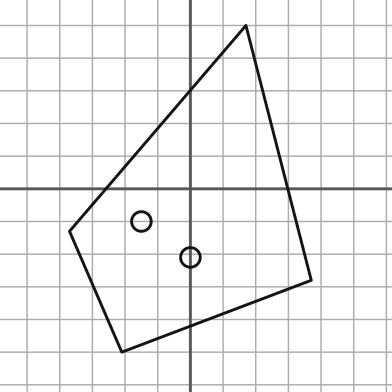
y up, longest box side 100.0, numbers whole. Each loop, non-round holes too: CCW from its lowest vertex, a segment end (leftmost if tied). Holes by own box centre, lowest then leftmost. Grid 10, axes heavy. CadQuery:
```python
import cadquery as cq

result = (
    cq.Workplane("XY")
    .moveTo(-21.0, -50.0)
    .lineTo(37.0, -28.0)
    .lineTo(17.0, 50.0)
    .lineTo(-37.0, -13.0)
    .close()
    .moveTo(0.0, -21.0)
    .circle(3.0)
    .moveTo(-15.0, -10.0)
    .circle(3.0)
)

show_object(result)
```